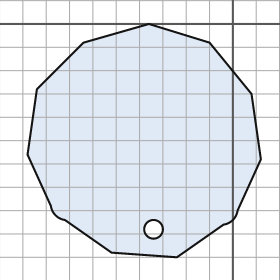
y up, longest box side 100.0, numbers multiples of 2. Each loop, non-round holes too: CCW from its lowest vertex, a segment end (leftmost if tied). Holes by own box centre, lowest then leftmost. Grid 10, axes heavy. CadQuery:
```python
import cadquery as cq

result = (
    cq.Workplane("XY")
    .moveTo(-24.0, -100.0)
    .lineTo(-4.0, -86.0)
    .threePointArc((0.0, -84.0), (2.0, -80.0))
    .lineTo(12.0, -58.0)
    .lineTo(8.0, -30.0)
    .lineTo(-10.0, -8.0)
    .lineTo(-36.0, 0.0)
    .lineTo(-64.0, -8.0)
    .lineTo(-84.0, -28.0)
    .lineTo(-88.0, -56.0)
    .lineTo(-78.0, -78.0)
    .threePointArc((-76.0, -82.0), (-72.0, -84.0))
    .lineTo(-52.0, -98.0)
    .close()
    .moveTo(-34.0, -88.0)
    .circle(4.0)
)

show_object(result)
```